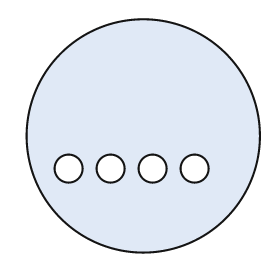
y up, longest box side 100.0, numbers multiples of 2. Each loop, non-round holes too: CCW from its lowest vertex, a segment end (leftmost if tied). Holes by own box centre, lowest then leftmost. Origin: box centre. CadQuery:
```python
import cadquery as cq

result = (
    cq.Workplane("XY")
    .moveTo(0.0, 0.0)
    .circle(50.0)
    .moveTo(-32.0, -14.0)
    .circle(6.0)
    .moveTo(-14.0, -14.0)
    .circle(6.0)
    .moveTo(4.0, -14.0)
    .circle(6.0)
    .moveTo(22.0, -14.0)
    .circle(6.0)
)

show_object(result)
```